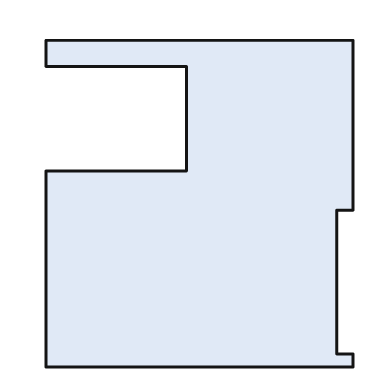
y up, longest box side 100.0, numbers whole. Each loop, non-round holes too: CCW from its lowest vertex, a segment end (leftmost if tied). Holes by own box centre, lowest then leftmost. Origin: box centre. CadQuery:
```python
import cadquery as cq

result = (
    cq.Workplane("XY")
    .moveTo(-47.0, -50.0)
    .lineTo(47.0, -50.0)
    .lineTo(47.0, -46.0)
    .lineTo(42.0, -46.0)
    .lineTo(42.0, -2.0)
    .lineTo(47.0, -2.0)
    .lineTo(47.0, 50.0)
    .lineTo(-47.0, 50.0)
    .lineTo(-47.0, 42.0)
    .lineTo(-4.0, 42.0)
    .lineTo(-4.0, 10.0)
    .lineTo(-47.0, 10.0)
    .close()
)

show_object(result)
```